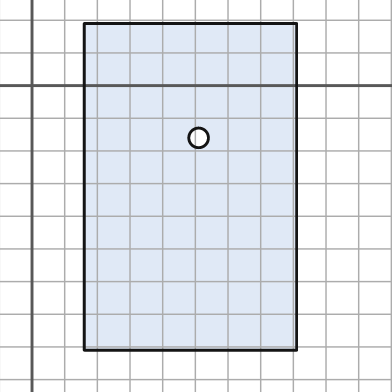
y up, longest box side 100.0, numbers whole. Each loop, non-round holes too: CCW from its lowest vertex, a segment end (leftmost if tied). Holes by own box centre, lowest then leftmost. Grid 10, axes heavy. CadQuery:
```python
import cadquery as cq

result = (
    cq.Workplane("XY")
    .moveTo(16.0, -81.0)
    .lineTo(81.0, -81.0)
    .lineTo(81.0, 19.0)
    .lineTo(16.0, 19.0)
    .close()
    .moveTo(51.0, -16.0)
    .circle(3.0)
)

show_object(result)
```